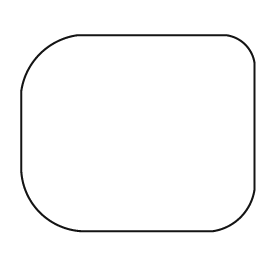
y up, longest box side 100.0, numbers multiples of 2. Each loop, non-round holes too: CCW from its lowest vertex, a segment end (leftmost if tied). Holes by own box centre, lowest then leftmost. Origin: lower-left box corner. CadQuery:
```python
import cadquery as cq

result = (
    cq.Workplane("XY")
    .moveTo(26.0, 0.0)
    .lineTo(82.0, 0.0)
    .threePointArc((94.0, 6.0), (100.0, 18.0))
    .lineTo(100.0, 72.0)
    .threePointArc((96.0, 80.0), (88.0, 84.0))
    .lineTo(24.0, 84.0)
    .threePointArc((8.0, 76.0), (0.0, 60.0))
    .lineTo(0.0, 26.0)
    .threePointArc((8.0, 8.0), (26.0, 0.0))
    .close()
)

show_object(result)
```